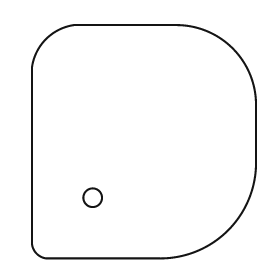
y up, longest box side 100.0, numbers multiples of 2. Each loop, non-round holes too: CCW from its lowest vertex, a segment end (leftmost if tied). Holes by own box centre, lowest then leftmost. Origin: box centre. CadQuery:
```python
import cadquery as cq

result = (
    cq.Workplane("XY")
    .moveTo(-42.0, -50.0)
    .lineTo(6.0, -50.0)
    .threePointArc((36.0, -38.0), (48.0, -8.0))
    .lineTo(48.0, 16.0)
    .threePointArc((38.0, 40.0), (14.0, 50.0))
    .lineTo(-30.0, 50.0)
    .threePointArc((-42.0, 44.0), (-48.0, 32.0))
    .lineTo(-48.0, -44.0)
    .threePointArc((-46.0, -48.0), (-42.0, -50.0))
    .close()
    .moveTo(-22.0, -24.0)
    .circle(4.0)
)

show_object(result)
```